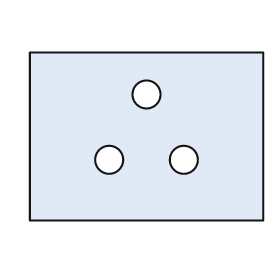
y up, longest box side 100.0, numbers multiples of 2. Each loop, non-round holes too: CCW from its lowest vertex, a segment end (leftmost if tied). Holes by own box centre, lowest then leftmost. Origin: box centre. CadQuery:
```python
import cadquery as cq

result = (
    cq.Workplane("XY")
    .moveTo(-50.0, -36.0)
    .lineTo(50.0, -36.0)
    .lineTo(50.0, 36.0)
    .lineTo(-50.0, 36.0)
    .close()
    .moveTo(-16.0, -10.0)
    .circle(6.0)
    .moveTo(16.0, -10.0)
    .circle(6.0)
    .moveTo(0.0, 18.0)
    .circle(6.0)
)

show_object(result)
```